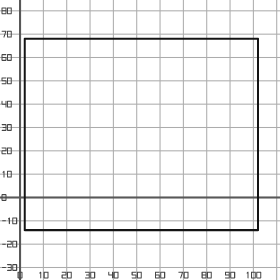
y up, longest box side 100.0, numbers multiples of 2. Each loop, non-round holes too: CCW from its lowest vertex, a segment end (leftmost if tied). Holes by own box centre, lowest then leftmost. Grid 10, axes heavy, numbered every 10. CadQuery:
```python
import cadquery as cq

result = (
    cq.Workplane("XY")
    .moveTo(2.0, -14.0)
    .lineTo(102.0, -14.0)
    .lineTo(102.0, 68.0)
    .lineTo(2.0, 68.0)
    .close()
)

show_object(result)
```